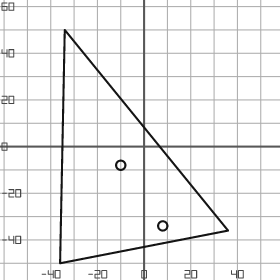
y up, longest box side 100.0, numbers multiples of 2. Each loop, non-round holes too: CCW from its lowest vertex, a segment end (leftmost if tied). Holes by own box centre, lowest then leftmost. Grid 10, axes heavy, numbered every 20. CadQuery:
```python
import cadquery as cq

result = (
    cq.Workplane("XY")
    .moveTo(-36.0, -50.0)
    .lineTo(36.0, -36.0)
    .lineTo(-34.0, 50.0)
    .close()
    .moveTo(8.0, -34.0)
    .circle(2.0)
    .moveTo(-10.0, -8.0)
    .circle(2.0)
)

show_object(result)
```